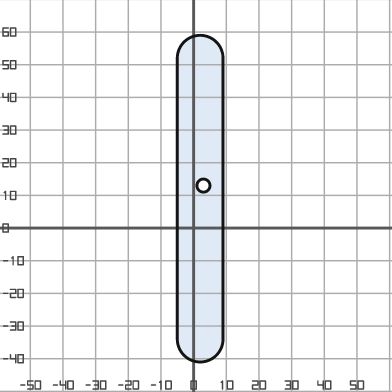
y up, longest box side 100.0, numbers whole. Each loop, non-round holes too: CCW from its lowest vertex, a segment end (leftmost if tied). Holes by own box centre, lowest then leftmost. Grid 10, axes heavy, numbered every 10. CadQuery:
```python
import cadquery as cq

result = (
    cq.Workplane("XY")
    .moveTo(-5.0, -34.0)
    .threePointArc((2.0, -41.0), (9.0, -34.0))
    .lineTo(9.0, 52.0)
    .threePointArc((2.0, 59.0), (-5.0, 52.0))
    .close()
    .moveTo(3.0, 13.0)
    .circle(2.0)
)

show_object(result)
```